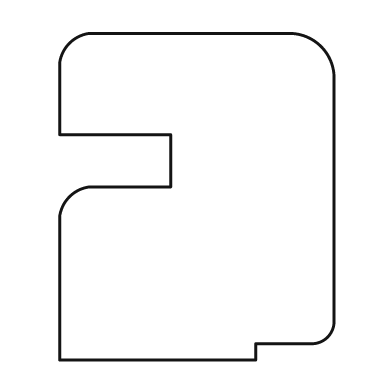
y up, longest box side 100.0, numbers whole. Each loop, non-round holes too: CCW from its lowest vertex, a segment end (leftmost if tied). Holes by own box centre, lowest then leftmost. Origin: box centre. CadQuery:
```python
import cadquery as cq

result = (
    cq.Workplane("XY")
    .moveTo(-42.0, -50.0)
    .lineTo(18.0, -50.0)
    .lineTo(18.0, -45.0)
    .lineTo(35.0, -45.0)
    .threePointArc((40.0, -43.0), (42.0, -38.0))
    .lineTo(42.0, 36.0)
    .threePointArc((38.0, 46.0), (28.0, 50.0))
    .lineTo(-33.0, 50.0)
    .threePointArc((-39.0, 47.0), (-42.0, 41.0))
    .lineTo(-42.0, 19.0)
    .lineTo(-8.0, 19.0)
    .lineTo(-8.0, 3.0)
    .lineTo(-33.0, 3.0)
    .threePointArc((-39.0, 0.0), (-42.0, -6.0))
    .close()
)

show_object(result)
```